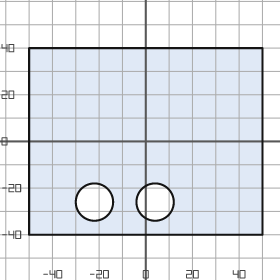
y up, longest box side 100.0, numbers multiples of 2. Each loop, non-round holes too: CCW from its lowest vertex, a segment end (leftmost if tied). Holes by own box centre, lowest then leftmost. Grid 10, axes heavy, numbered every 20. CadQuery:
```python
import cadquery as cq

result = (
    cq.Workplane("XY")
    .moveTo(-50.0, -40.0)
    .lineTo(50.0, -40.0)
    .lineTo(50.0, 40.0)
    .lineTo(-50.0, 40.0)
    .close()
    .moveTo(-22.0, -26.0)
    .circle(8.0)
    .moveTo(4.0, -26.0)
    .circle(8.0)
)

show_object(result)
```